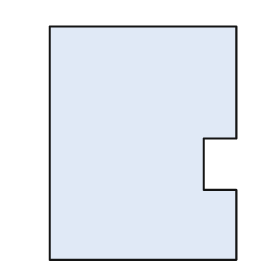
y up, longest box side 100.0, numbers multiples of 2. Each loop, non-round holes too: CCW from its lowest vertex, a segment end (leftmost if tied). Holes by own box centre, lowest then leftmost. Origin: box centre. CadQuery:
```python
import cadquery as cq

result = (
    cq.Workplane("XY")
    .moveTo(-40.0, -50.0)
    .lineTo(40.0, -50.0)
    .lineTo(40.0, -20.0)
    .lineTo(26.0, -20.0)
    .lineTo(26.0, 2.0)
    .lineTo(40.0, 2.0)
    .lineTo(40.0, 50.0)
    .lineTo(-40.0, 50.0)
    .close()
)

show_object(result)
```